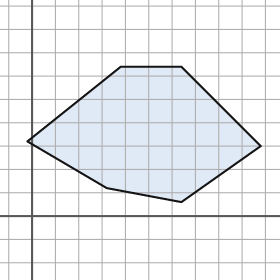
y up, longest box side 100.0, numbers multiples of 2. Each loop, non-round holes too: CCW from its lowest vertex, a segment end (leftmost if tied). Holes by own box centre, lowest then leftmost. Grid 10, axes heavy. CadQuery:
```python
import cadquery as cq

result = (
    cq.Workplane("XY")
    .moveTo(64.0, 6.0)
    .lineTo(98.0, 30.0)
    .lineTo(64.0, 64.0)
    .lineTo(38.0, 64.0)
    .lineTo(-2.0, 32.0)
    .lineTo(32.0, 12.0)
    .close()
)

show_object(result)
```